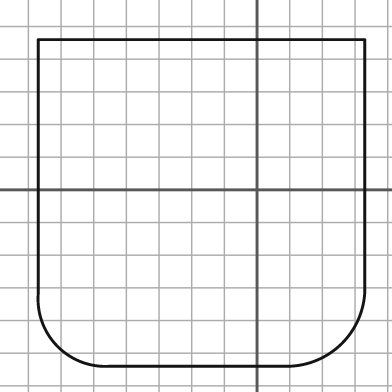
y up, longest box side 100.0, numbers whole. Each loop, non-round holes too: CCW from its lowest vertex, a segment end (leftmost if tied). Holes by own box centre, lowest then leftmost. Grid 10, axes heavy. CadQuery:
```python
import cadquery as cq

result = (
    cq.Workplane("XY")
    .moveTo(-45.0, -54.0)
    .lineTo(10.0, -54.0)
    .threePointArc((26.0, -47.0), (33.0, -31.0))
    .lineTo(33.0, 46.0)
    .lineTo(-67.0, 46.0)
    .lineTo(-67.0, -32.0)
    .threePointArc((-61.0, -48.0), (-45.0, -54.0))
    .close()
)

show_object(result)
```